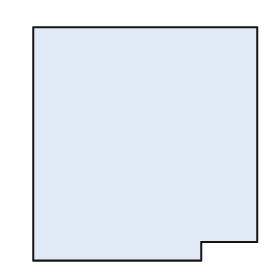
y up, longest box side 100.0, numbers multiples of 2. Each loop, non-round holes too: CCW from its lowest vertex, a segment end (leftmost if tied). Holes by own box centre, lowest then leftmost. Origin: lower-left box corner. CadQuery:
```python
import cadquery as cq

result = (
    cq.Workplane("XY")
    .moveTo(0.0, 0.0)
    .lineTo(72.0, 0.0)
    .lineTo(72.0, 8.0)
    .lineTo(96.0, 8.0)
    .lineTo(96.0, 100.0)
    .lineTo(0.0, 100.0)
    .close()
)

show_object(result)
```